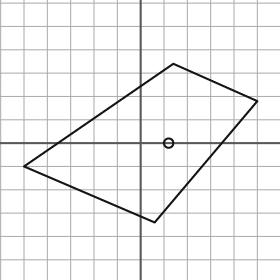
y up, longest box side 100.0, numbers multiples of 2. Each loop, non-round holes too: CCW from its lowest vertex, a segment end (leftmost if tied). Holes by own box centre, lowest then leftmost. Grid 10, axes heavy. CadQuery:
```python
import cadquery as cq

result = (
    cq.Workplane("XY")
    .moveTo(6.0, -34.0)
    .lineTo(50.0, 18.0)
    .lineTo(14.0, 34.0)
    .lineTo(-50.0, -10.0)
    .close()
    .moveTo(12.0, 0.0)
    .circle(2.0)
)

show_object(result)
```